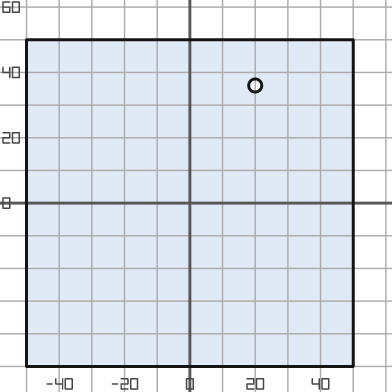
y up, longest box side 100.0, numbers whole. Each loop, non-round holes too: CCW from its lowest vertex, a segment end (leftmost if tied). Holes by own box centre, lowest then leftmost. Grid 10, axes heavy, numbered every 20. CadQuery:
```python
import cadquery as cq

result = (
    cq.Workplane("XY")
    .moveTo(-50.0, -50.0)
    .lineTo(50.0, -50.0)
    .lineTo(50.0, 50.0)
    .lineTo(-50.0, 50.0)
    .close()
    .moveTo(20.0, 36.0)
    .circle(2.0)
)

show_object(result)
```